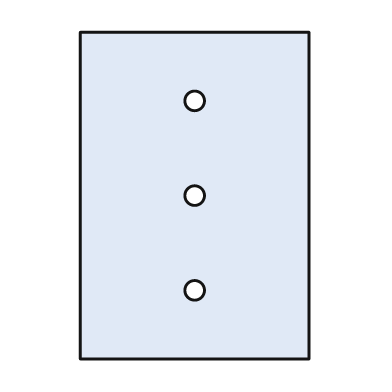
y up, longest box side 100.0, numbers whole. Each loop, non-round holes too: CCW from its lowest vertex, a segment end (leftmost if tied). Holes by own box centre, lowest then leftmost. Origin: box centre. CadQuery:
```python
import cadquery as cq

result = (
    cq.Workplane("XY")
    .moveTo(-35.0, -50.0)
    .lineTo(35.0, -50.0)
    .lineTo(35.0, 50.0)
    .lineTo(-35.0, 50.0)
    .close()
    .moveTo(0.0, -29.0)
    .circle(3.0)
    .moveTo(0.0, 0.0)
    .circle(3.0)
    .moveTo(0.0, 29.0)
    .circle(3.0)
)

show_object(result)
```